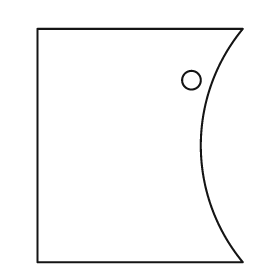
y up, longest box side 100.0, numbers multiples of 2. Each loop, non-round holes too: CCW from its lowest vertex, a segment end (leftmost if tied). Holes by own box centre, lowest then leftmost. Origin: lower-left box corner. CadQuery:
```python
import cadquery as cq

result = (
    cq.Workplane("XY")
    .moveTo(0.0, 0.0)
    .lineTo(88.0, 0.0)
    .threePointArc((70.0, 50.0), (88.0, 100.0))
    .lineTo(0.0, 100.0)
    .close()
    .moveTo(66.0, 78.0)
    .circle(4.0)
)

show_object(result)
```